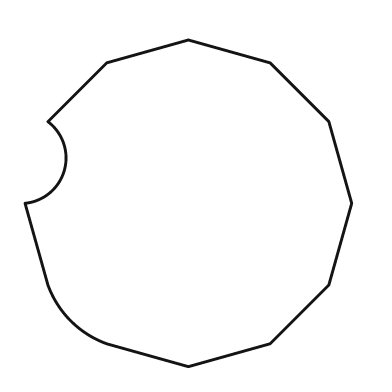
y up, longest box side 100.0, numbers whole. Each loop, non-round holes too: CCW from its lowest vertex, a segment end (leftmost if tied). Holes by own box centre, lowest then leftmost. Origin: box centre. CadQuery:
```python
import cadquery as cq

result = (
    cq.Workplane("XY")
    .moveTo(0.0, -50.0)
    .lineTo(25.0, -43.0)
    .lineTo(43.0, -25.0)
    .lineTo(50.0, 0.0)
    .lineTo(43.0, 25.0)
    .lineTo(25.0, 43.0)
    .lineTo(0.0, 50.0)
    .lineTo(-25.0, 43.0)
    .lineTo(-43.0, 25.0)
    .threePointArc((-38.0, 10.0), (-50.0, 0.0))
    .lineTo(-43.0, -25.0)
    .threePointArc((-36.0, -36.0), (-25.0, -43.0))
    .close()
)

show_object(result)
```